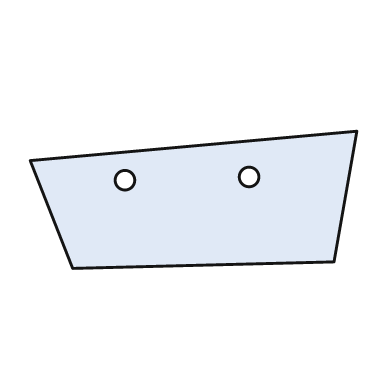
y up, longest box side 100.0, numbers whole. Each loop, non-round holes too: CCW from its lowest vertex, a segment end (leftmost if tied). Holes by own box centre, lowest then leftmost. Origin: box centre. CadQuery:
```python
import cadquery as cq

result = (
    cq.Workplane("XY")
    .moveTo(-37.0, -21.0)
    .lineTo(43.0, -19.0)
    .lineTo(50.0, 21.0)
    .lineTo(-50.0, 12.0)
    .close()
    .moveTo(-21.0, 6.0)
    .circle(3.0)
    .moveTo(17.0, 7.0)
    .circle(3.0)
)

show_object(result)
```